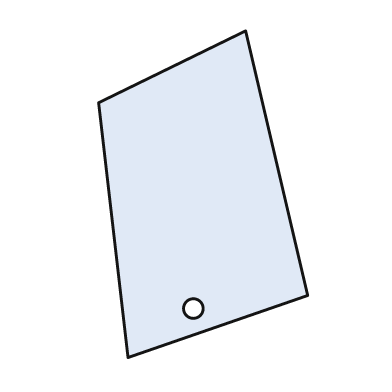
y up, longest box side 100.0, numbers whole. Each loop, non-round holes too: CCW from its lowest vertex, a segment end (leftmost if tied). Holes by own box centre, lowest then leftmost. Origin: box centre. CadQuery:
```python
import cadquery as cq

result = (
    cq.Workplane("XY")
    .moveTo(-23.0, -50.0)
    .lineTo(32.0, -31.0)
    .lineTo(13.0, 50.0)
    .lineTo(-32.0, 28.0)
    .close()
    .moveTo(-3.0, -35.0)
    .circle(3.0)
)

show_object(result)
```